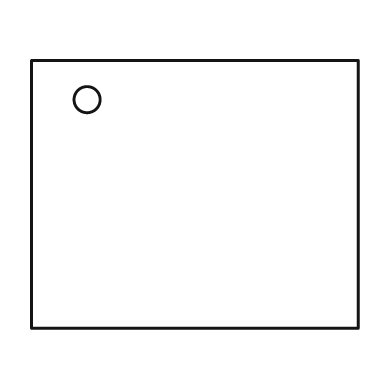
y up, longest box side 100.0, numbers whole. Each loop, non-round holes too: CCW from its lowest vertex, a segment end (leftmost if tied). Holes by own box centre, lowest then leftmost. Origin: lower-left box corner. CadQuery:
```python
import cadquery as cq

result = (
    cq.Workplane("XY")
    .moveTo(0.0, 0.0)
    .lineTo(100.0, 0.0)
    .lineTo(100.0, 82.0)
    .lineTo(0.0, 82.0)
    .close()
    .moveTo(17.0, 70.0)
    .circle(4.0)
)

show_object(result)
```